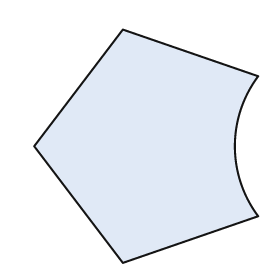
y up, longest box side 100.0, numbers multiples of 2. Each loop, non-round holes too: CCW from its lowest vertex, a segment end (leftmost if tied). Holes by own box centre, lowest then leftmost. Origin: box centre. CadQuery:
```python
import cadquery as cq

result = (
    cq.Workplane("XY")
    .moveTo(-10.0, -50.0)
    .lineTo(48.0, -30.0)
    .threePointArc((38.0, 0.0), (48.0, 30.0))
    .lineTo(-10.0, 50.0)
    .lineTo(-48.0, 0.0)
    .close()
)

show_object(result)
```